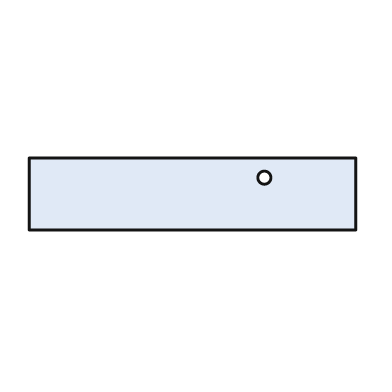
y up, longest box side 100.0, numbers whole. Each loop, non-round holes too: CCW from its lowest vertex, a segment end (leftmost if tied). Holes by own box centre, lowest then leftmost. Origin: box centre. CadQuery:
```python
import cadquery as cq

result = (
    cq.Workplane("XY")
    .moveTo(-50.0, -11.0)
    .lineTo(50.0, -11.0)
    .lineTo(50.0, 11.0)
    .lineTo(-50.0, 11.0)
    .close()
    .moveTo(22.0, 5.0)
    .circle(2.0)
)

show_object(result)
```